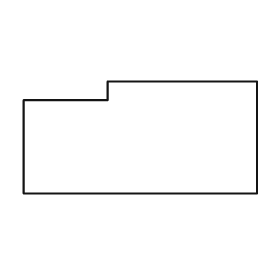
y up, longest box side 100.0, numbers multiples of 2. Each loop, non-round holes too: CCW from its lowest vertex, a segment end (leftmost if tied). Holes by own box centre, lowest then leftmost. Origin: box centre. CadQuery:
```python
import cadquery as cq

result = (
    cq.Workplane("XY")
    .moveTo(-50.0, -24.0)
    .lineTo(50.0, -24.0)
    .lineTo(50.0, 24.0)
    .lineTo(-14.0, 24.0)
    .lineTo(-14.0, 16.0)
    .lineTo(-50.0, 16.0)
    .close()
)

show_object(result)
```